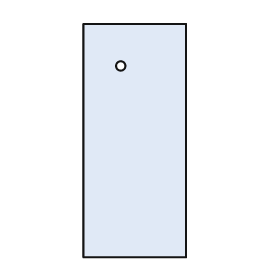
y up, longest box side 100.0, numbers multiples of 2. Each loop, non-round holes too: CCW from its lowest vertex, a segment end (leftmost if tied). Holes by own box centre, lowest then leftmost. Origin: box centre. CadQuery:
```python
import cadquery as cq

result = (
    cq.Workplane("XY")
    .moveTo(-22.0, -50.0)
    .lineTo(22.0, -50.0)
    .lineTo(22.0, 50.0)
    .lineTo(-22.0, 50.0)
    .close()
    .moveTo(-6.0, 32.0)
    .circle(2.0)
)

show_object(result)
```